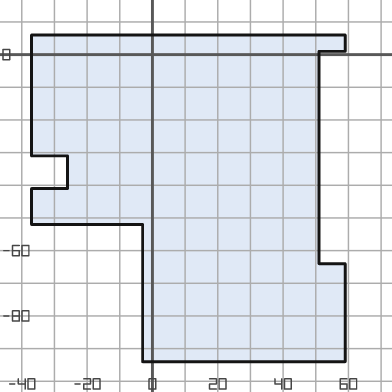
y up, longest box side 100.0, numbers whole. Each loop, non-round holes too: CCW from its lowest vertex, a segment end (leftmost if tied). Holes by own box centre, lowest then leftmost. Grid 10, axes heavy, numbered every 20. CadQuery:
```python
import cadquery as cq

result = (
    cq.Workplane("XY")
    .moveTo(-3.0, -94.0)
    .lineTo(59.0, -94.0)
    .lineTo(59.0, -64.0)
    .lineTo(51.0, -64.0)
    .lineTo(51.0, 1.0)
    .lineTo(59.0, 1.0)
    .lineTo(59.0, 6.0)
    .lineTo(-37.0, 6.0)
    .lineTo(-37.0, -31.0)
    .lineTo(-26.0, -31.0)
    .lineTo(-26.0, -41.0)
    .lineTo(-37.0, -41.0)
    .lineTo(-37.0, -52.0)
    .lineTo(-3.0, -52.0)
    .close()
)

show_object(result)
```